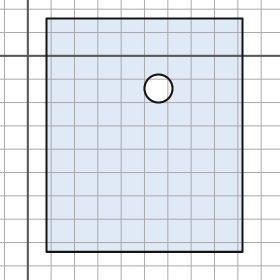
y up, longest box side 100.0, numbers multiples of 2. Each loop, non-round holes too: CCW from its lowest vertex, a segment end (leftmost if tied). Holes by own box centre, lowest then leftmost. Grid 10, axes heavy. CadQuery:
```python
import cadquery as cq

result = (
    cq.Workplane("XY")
    .moveTo(8.0, -84.0)
    .lineTo(92.0, -84.0)
    .lineTo(92.0, 16.0)
    .lineTo(8.0, 16.0)
    .close()
    .moveTo(56.0, -14.0)
    .circle(6.0)
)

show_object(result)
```